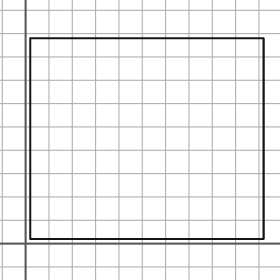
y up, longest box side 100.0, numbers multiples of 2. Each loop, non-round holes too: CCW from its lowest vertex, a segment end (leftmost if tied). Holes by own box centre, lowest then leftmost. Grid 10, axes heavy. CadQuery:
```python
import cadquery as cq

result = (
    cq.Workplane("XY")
    .moveTo(2.0, 2.0)
    .lineTo(102.0, 2.0)
    .lineTo(102.0, 88.0)
    .lineTo(2.0, 88.0)
    .close()
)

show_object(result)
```